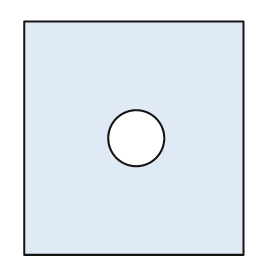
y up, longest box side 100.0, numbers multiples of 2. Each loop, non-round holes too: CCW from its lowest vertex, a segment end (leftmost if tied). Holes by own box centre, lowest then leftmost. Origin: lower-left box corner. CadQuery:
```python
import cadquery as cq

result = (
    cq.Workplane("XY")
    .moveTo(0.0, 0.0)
    .lineTo(94.0, 0.0)
    .lineTo(94.0, 100.0)
    .lineTo(0.0, 100.0)
    .close()
    .moveTo(48.0, 50.0)
    .circle(12.0)
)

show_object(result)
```